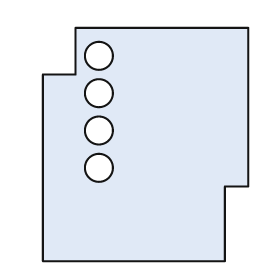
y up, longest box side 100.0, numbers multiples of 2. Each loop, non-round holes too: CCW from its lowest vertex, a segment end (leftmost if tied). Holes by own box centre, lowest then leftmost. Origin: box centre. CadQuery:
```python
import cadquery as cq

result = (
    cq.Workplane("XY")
    .moveTo(-44.0, -50.0)
    .lineTo(34.0, -50.0)
    .lineTo(34.0, -18.0)
    .lineTo(44.0, -18.0)
    .lineTo(44.0, 50.0)
    .lineTo(-30.0, 50.0)
    .lineTo(-30.0, 30.0)
    .lineTo(-44.0, 30.0)
    .close()
    .moveTo(-20.0, -10.0)
    .circle(6.0)
    .moveTo(-20.0, 6.0)
    .circle(6.0)
    .moveTo(-20.0, 22.0)
    .circle(6.0)
    .moveTo(-20.0, 38.0)
    .circle(6.0)
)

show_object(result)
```